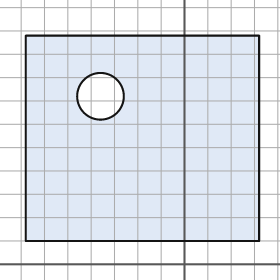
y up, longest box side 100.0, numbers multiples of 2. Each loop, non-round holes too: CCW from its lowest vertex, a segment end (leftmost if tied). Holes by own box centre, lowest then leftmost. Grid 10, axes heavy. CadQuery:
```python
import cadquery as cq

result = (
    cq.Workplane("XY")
    .moveTo(-68.0, 10.0)
    .lineTo(32.0, 10.0)
    .lineTo(32.0, 98.0)
    .lineTo(-68.0, 98.0)
    .close()
    .moveTo(-36.0, 72.0)
    .circle(10.0)
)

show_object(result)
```